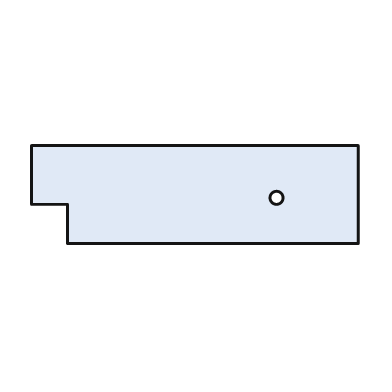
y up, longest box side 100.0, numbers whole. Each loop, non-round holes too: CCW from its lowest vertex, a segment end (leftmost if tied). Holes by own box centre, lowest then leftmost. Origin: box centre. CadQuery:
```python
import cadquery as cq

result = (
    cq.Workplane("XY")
    .moveTo(-39.0, -15.0)
    .lineTo(50.0, -15.0)
    .lineTo(50.0, 15.0)
    .lineTo(-50.0, 15.0)
    .lineTo(-50.0, -3.0)
    .lineTo(-39.0, -3.0)
    .close()
    .moveTo(25.0, -1.0)
    .circle(2.0)
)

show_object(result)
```